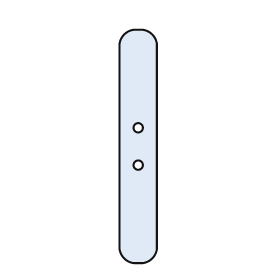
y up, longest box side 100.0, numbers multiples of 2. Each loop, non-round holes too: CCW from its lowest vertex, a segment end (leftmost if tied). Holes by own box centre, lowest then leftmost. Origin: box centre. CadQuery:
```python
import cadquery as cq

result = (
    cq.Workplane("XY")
    .moveTo(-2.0, -50.0)
    .lineTo(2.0, -50.0)
    .threePointArc((6.0, -48.0), (8.0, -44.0))
    .lineTo(8.0, 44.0)
    .threePointArc((6.0, 48.0), (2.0, 50.0))
    .lineTo(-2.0, 50.0)
    .threePointArc((-6.0, 48.0), (-8.0, 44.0))
    .lineTo(-8.0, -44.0)
    .threePointArc((-6.0, -48.0), (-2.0, -50.0))
    .close()
    .moveTo(0.0, -8.0)
    .circle(2.0)
    .moveTo(0.0, 8.0)
    .circle(2.0)
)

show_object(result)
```